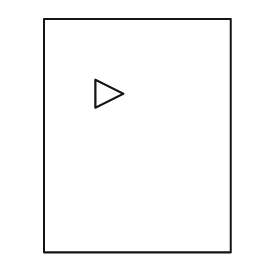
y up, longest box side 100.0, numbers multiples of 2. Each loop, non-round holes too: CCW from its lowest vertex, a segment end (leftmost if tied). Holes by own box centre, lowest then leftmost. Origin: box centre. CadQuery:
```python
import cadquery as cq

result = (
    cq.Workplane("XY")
    .moveTo(-40.0, -50.0)
    .lineTo(40.0, -50.0)
    .lineTo(40.0, 50.0)
    .lineTo(-40.0, 50.0)
    .close()
    .moveTo(-18.0, 12.0)
    .lineTo(-6.0, 18.0)
    .lineTo(-18.0, 24.0)
    .close()
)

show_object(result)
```